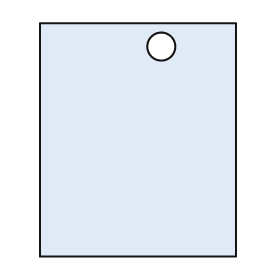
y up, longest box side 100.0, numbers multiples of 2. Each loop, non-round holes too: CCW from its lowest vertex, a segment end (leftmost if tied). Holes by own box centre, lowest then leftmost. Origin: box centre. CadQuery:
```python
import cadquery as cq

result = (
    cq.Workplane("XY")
    .moveTo(-42.0, -50.0)
    .lineTo(42.0, -50.0)
    .lineTo(42.0, 50.0)
    .lineTo(-42.0, 50.0)
    .close()
    .moveTo(10.0, 40.0)
    .circle(6.0)
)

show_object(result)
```